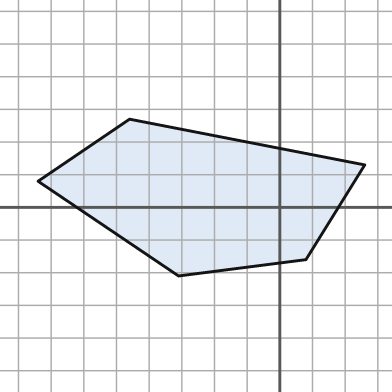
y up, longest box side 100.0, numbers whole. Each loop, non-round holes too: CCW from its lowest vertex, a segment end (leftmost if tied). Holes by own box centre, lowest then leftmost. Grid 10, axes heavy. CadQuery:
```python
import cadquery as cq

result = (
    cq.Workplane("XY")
    .moveTo(-31.0, -21.0)
    .lineTo(8.0, -16.0)
    .lineTo(26.0, 13.0)
    .lineTo(-46.0, 27.0)
    .lineTo(-74.0, 8.0)
    .close()
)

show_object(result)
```